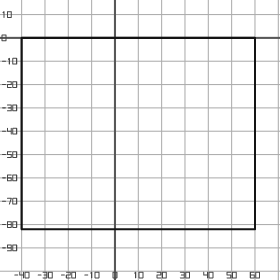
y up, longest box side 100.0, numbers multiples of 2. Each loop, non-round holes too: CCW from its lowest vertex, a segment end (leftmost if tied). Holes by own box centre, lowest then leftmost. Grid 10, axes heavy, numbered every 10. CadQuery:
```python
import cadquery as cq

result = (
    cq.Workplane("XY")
    .moveTo(-40.0, -82.0)
    .lineTo(60.0, -82.0)
    .lineTo(60.0, 0.0)
    .lineTo(-40.0, 0.0)
    .close()
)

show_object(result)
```